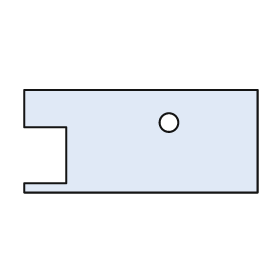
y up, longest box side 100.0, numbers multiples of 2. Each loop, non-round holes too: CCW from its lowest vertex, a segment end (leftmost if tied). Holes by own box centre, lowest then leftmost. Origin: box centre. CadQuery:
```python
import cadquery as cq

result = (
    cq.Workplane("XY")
    .moveTo(-50.0, -22.0)
    .lineTo(50.0, -22.0)
    .lineTo(50.0, 22.0)
    .lineTo(-50.0, 22.0)
    .lineTo(-50.0, 6.0)
    .lineTo(-32.0, 6.0)
    .lineTo(-32.0, -18.0)
    .lineTo(-50.0, -18.0)
    .close()
    .moveTo(12.0, 8.0)
    .circle(4.0)
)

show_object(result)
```